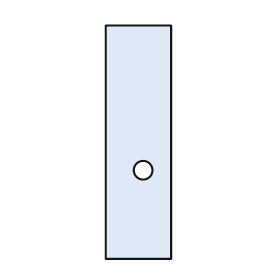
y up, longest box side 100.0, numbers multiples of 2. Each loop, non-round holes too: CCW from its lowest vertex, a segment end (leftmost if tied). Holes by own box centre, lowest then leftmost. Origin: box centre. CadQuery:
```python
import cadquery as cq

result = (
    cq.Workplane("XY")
    .moveTo(-14.0, -50.0)
    .lineTo(14.0, -50.0)
    .lineTo(14.0, 50.0)
    .lineTo(-14.0, 50.0)
    .close()
    .moveTo(2.0, -12.0)
    .circle(4.0)
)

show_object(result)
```